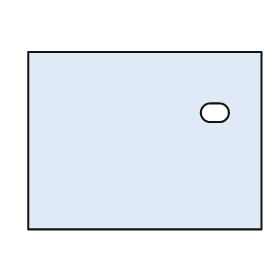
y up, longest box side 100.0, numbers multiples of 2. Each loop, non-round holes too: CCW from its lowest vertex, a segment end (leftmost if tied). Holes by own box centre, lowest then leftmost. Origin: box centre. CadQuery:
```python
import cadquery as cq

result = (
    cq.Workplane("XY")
    .moveTo(-50.0, -38.0)
    .lineTo(50.0, -38.0)
    .lineTo(50.0, 38.0)
    .lineTo(-50.0, 38.0)
    .close()
    .moveTo(28.0, 8.0)
    .lineTo(32.0, 8.0)
    .threePointArc((36.0, 12.0), (32.0, 16.0))
    .lineTo(28.0, 16.0)
    .threePointArc((24.0, 12.0), (28.0, 8.0))
    .close()
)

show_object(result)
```